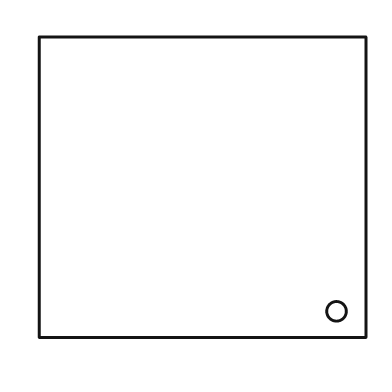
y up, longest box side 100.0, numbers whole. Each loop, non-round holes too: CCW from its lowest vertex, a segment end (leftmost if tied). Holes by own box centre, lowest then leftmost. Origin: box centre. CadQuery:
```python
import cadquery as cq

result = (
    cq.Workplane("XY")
    .moveTo(-50.0, -46.0)
    .lineTo(50.0, -46.0)
    .lineTo(50.0, 46.0)
    .lineTo(-50.0, 46.0)
    .close()
    .moveTo(41.0, -38.0)
    .circle(3.0)
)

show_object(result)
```